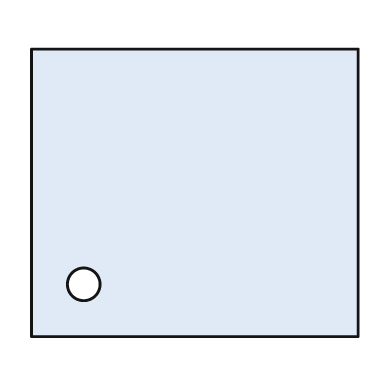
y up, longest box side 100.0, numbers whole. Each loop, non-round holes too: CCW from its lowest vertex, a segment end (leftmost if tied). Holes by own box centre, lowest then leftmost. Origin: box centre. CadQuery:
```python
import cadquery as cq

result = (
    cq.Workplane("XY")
    .moveTo(-50.0, -44.0)
    .lineTo(50.0, -44.0)
    .lineTo(50.0, 44.0)
    .lineTo(-50.0, 44.0)
    .close()
    .moveTo(-34.0, -28.0)
    .circle(5.0)
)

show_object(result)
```